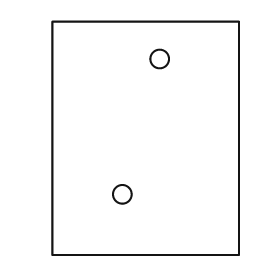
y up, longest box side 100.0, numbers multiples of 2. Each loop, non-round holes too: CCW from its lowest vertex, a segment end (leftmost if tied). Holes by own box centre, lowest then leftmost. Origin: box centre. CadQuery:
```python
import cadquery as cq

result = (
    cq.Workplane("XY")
    .moveTo(-40.0, -50.0)
    .lineTo(40.0, -50.0)
    .lineTo(40.0, 50.0)
    .lineTo(-40.0, 50.0)
    .close()
    .moveTo(-10.0, -24.0)
    .circle(4.0)
    .moveTo(6.0, 34.0)
    .circle(4.0)
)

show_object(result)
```